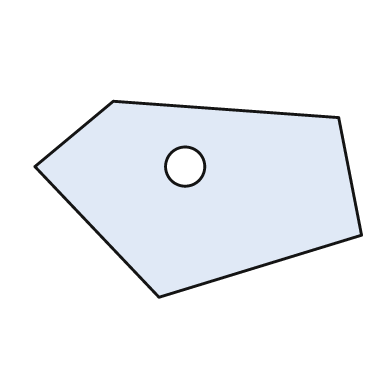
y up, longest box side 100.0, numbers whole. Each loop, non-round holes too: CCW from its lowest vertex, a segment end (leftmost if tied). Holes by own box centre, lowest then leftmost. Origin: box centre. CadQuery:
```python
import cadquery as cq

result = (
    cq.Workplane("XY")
    .moveTo(-12.0, -30.0)
    .lineTo(50.0, -11.0)
    .lineTo(43.0, 25.0)
    .lineTo(-26.0, 30.0)
    .lineTo(-50.0, 10.0)
    .close()
    .moveTo(-4.0, 10.0)
    .circle(6.0)
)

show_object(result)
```